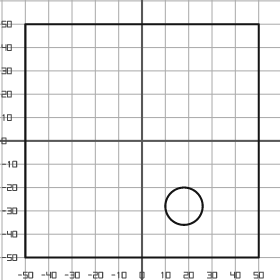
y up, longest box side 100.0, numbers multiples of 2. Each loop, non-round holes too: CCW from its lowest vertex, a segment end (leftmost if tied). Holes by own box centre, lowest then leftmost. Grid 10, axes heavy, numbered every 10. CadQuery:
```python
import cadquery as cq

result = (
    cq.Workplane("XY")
    .moveTo(-50.0, -50.0)
    .lineTo(50.0, -50.0)
    .lineTo(50.0, 50.0)
    .lineTo(-50.0, 50.0)
    .close()
    .moveTo(18.0, -28.0)
    .circle(8.0)
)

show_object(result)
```